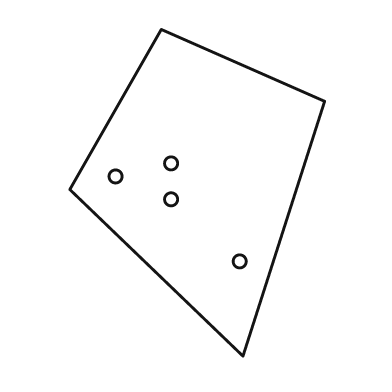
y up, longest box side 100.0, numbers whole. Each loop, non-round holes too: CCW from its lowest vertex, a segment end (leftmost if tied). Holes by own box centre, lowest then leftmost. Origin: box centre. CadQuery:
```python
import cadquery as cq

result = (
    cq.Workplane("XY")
    .moveTo(14.0, -50.0)
    .lineTo(39.0, 28.0)
    .lineTo(-11.0, 50.0)
    .lineTo(-39.0, 1.0)
    .close()
    .moveTo(13.0, -21.0)
    .circle(2.0)
    .moveTo(-8.0, -2.0)
    .circle(2.0)
    .moveTo(-25.0, 5.0)
    .circle(2.0)
    .moveTo(-8.0, 9.0)
    .circle(2.0)
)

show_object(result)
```